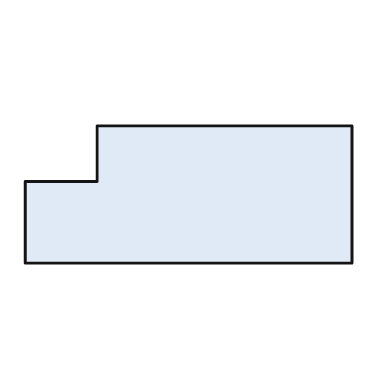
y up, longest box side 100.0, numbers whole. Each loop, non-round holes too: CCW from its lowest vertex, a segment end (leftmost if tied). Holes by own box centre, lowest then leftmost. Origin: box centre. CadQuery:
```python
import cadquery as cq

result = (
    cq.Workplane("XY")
    .moveTo(-50.0, -21.0)
    .lineTo(50.0, -21.0)
    .lineTo(50.0, 21.0)
    .lineTo(-28.0, 21.0)
    .lineTo(-28.0, 4.0)
    .lineTo(-50.0, 4.0)
    .close()
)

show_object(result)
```